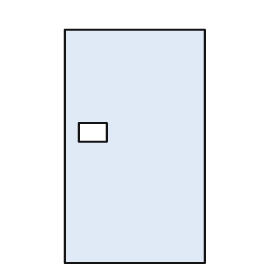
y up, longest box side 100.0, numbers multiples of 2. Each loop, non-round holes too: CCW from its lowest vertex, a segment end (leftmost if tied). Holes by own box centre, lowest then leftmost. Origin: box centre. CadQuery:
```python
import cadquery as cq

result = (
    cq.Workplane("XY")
    .moveTo(-30.0, -50.0)
    .lineTo(30.0, -50.0)
    .lineTo(30.0, 50.0)
    .lineTo(-30.0, 50.0)
    .close()
    .moveTo(-24.0, 2.0)
    .lineTo(-12.0, 2.0)
    .lineTo(-12.0, 10.0)
    .lineTo(-24.0, 10.0)
    .close()
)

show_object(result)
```